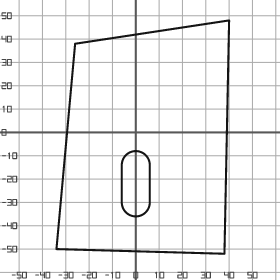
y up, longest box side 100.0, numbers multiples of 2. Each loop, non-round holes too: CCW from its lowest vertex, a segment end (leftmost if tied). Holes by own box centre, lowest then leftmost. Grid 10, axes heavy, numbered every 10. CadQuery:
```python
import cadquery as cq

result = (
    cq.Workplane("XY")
    .moveTo(38.0, -52.0)
    .lineTo(40.0, 48.0)
    .lineTo(-26.0, 38.0)
    .lineTo(-34.0, -50.0)
    .close()
    .moveTo(-6.0, -30.0)
    .threePointArc((0.0, -36.0), (6.0, -30.0))
    .lineTo(6.0, -14.0)
    .threePointArc((0.0, -8.0), (-6.0, -14.0))
    .close()
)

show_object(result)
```